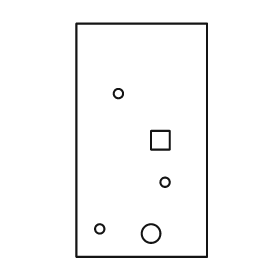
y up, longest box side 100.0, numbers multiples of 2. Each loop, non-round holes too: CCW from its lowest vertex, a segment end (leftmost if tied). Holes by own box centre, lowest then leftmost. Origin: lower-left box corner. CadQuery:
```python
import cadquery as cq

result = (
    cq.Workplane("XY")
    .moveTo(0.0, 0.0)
    .lineTo(56.0, 0.0)
    .lineTo(56.0, 100.0)
    .lineTo(0.0, 100.0)
    .close()
    .moveTo(32.0, 10.0)
    .circle(4.0)
    .moveTo(10.0, 12.0)
    .circle(2.0)
    .moveTo(38.0, 32.0)
    .circle(2.0)
    .moveTo(32.0, 46.0)
    .lineTo(40.0, 46.0)
    .lineTo(40.0, 54.0)
    .lineTo(32.0, 54.0)
    .close()
    .moveTo(18.0, 70.0)
    .circle(2.0)
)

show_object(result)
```